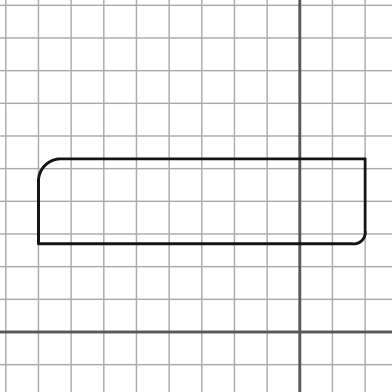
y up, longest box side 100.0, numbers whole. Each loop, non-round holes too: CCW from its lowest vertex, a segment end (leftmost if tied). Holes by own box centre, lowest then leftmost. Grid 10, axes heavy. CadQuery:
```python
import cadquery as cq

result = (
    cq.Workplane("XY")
    .moveTo(-80.0, 27.0)
    .lineTo(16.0, 27.0)
    .threePointArc((19.0, 28.0), (20.0, 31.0))
    .lineTo(20.0, 53.0)
    .lineTo(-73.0, 53.0)
    .threePointArc((-78.0, 51.0), (-80.0, 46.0))
    .close()
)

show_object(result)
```